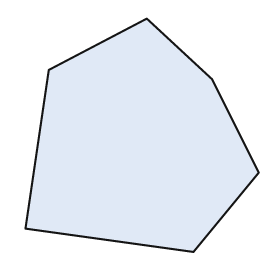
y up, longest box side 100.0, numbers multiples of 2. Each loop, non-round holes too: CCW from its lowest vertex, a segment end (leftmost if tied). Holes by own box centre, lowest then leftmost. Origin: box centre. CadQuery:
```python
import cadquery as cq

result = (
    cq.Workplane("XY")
    .moveTo(22.0, -50.0)
    .lineTo(50.0, -16.0)
    .lineTo(30.0, 24.0)
    .lineTo(2.0, 50.0)
    .lineTo(-40.0, 28.0)
    .lineTo(-50.0, -40.0)
    .close()
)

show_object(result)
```